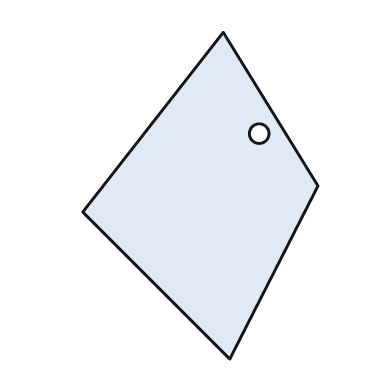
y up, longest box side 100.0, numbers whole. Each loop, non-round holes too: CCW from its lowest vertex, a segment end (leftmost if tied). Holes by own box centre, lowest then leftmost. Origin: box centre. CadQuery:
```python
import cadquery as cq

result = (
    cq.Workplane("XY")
    .moveTo(9.0, -50.0)
    .lineTo(36.0, 3.0)
    .lineTo(7.0, 50.0)
    .lineTo(-36.0, -5.0)
    .close()
    .moveTo(18.0, 19.0)
    .circle(3.0)
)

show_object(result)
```